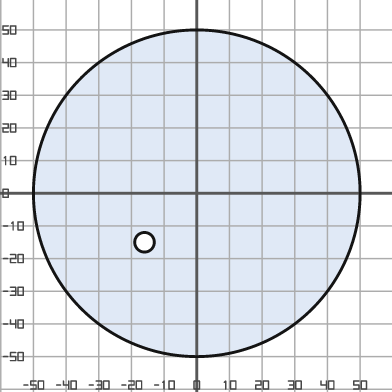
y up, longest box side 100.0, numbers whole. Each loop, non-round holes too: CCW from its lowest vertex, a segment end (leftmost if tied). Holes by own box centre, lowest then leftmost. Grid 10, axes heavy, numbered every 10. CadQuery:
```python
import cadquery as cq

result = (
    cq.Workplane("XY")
    .moveTo(0.0, 0.0)
    .circle(50.0)
    .moveTo(-16.0, -15.0)
    .circle(3.0)
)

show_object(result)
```